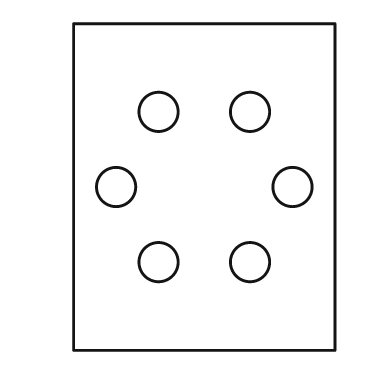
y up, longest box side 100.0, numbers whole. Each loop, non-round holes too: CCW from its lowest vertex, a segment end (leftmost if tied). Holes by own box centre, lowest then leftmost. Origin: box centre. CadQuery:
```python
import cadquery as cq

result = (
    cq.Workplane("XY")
    .moveTo(-40.0, -50.0)
    .lineTo(40.0, -50.0)
    .lineTo(40.0, 50.0)
    .lineTo(-40.0, 50.0)
    .close()
    .moveTo(-14.0, -23.0)
    .circle(6.0)
    .moveTo(14.0, -23.0)
    .circle(6.0)
    .moveTo(-27.0, 0.0)
    .circle(6.0)
    .moveTo(27.0, 0.0)
    .circle(6.0)
    .moveTo(-14.0, 23.0)
    .circle(6.0)
    .moveTo(14.0, 23.0)
    .circle(6.0)
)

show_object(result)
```